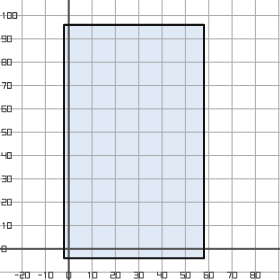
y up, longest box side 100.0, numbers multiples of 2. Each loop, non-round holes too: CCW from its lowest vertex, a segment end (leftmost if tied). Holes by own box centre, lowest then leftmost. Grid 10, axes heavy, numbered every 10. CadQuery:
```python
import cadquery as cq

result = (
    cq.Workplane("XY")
    .moveTo(-2.0, -4.0)
    .lineTo(58.0, -4.0)
    .lineTo(58.0, 96.0)
    .lineTo(-2.0, 96.0)
    .close()
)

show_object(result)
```